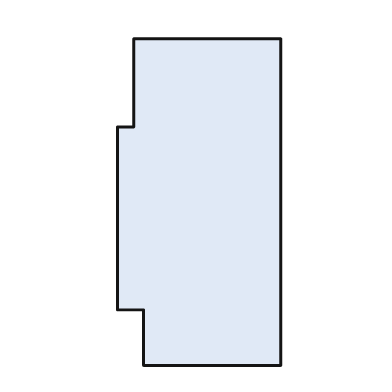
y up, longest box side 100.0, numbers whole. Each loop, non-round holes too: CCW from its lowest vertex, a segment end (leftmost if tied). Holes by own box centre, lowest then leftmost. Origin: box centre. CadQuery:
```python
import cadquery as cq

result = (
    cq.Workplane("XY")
    .moveTo(-17.0, -50.0)
    .lineTo(25.0, -50.0)
    .lineTo(25.0, 50.0)
    .lineTo(-20.0, 50.0)
    .lineTo(-20.0, 23.0)
    .lineTo(-25.0, 23.0)
    .lineTo(-25.0, -33.0)
    .lineTo(-17.0, -33.0)
    .close()
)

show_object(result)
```